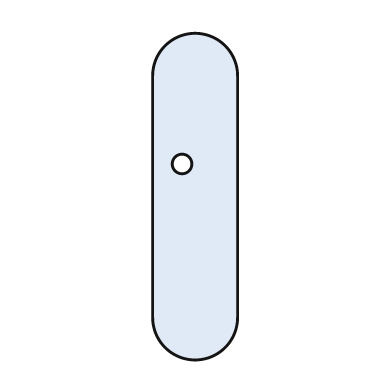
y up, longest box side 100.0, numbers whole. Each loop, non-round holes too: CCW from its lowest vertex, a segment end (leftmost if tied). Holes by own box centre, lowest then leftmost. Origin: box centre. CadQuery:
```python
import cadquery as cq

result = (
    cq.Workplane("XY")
    .moveTo(-13.0, -37.0)
    .threePointArc((0.0, -50.0), (13.0, -37.0))
    .lineTo(13.0, 37.0)
    .threePointArc((0.0, 50.0), (-13.0, 37.0))
    .close()
    .moveTo(-4.0, 10.0)
    .circle(3.0)
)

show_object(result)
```